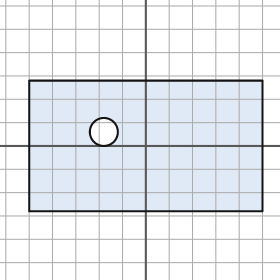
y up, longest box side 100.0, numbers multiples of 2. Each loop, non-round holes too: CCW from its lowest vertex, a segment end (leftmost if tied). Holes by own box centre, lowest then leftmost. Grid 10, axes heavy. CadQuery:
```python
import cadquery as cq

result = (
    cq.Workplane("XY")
    .moveTo(-50.0, -28.0)
    .lineTo(50.0, -28.0)
    .lineTo(50.0, 28.0)
    .lineTo(-50.0, 28.0)
    .close()
    .moveTo(-18.0, 6.0)
    .circle(6.0)
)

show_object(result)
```